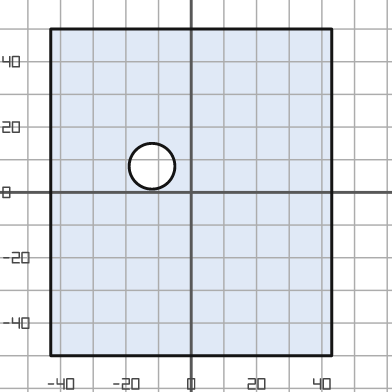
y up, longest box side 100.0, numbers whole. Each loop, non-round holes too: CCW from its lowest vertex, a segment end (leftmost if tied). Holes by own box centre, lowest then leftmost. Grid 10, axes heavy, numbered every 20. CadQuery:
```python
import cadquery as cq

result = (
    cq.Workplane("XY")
    .moveTo(-43.0, -50.0)
    .lineTo(43.0, -50.0)
    .lineTo(43.0, 50.0)
    .lineTo(-43.0, 50.0)
    .close()
    .moveTo(-12.0, 8.0)
    .circle(7.0)
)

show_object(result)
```